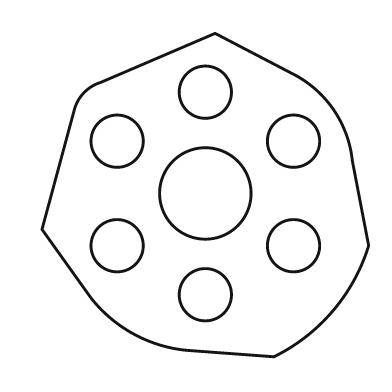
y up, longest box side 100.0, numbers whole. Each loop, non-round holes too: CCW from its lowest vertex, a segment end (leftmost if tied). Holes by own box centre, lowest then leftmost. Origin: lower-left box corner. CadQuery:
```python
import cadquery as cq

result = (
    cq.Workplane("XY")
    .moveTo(71.0, 0.0)
    .threePointArc((89.0, 14.0), (100.0, 34.0))
    .lineTo(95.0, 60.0)
    .threePointArc((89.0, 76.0), (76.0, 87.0))
    .lineTo(53.0, 99.0)
    .lineTo(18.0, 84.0)
    .threePointArc((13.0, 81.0), (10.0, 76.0))
    .lineTo(0.0, 39.0)
    .lineTo(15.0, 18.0)
    .threePointArc((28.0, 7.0), (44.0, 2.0))
    .close()
    .moveTo(50.0, 19.0)
    .circle(8.0)
    .moveTo(23.0, 34.0)
    .circle(8.0)
    .moveTo(77.0, 34.0)
    .circle(8.0)
    .moveTo(50.0, 50.0)
    .circle(14.0)
    .moveTo(23.0, 66.0)
    .circle(8.0)
    .moveTo(77.0, 66.0)
    .circle(8.0)
    .moveTo(50.0, 81.0)
    .circle(8.0)
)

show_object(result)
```